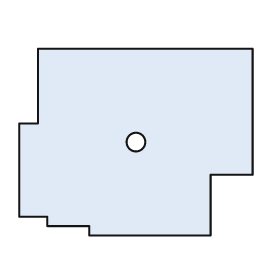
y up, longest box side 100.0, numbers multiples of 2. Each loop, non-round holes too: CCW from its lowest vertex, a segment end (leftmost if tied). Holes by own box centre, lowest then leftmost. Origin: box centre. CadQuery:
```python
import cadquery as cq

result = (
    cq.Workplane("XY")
    .moveTo(-20.0, -40.0)
    .lineTo(32.0, -40.0)
    .lineTo(32.0, -14.0)
    .lineTo(50.0, -14.0)
    .lineTo(50.0, 40.0)
    .lineTo(-42.0, 40.0)
    .lineTo(-42.0, 8.0)
    .lineTo(-50.0, 8.0)
    .lineTo(-50.0, -32.0)
    .lineTo(-38.0, -32.0)
    .lineTo(-38.0, -36.0)
    .lineTo(-20.0, -36.0)
    .close()
    .moveTo(0.0, 0.0)
    .circle(4.0)
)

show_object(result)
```